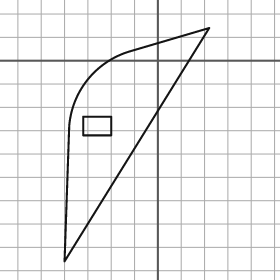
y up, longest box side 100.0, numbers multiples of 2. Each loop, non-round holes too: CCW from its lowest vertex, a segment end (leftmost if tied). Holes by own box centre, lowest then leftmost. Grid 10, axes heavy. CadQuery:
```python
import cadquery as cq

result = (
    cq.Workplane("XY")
    .moveTo(-40.0, -86.0)
    .lineTo(22.0, 14.0)
    .lineTo(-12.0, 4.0)
    .threePointArc((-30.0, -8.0), (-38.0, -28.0))
    .close()
    .moveTo(-32.0, -32.0)
    .lineTo(-20.0, -32.0)
    .lineTo(-20.0, -24.0)
    .lineTo(-32.0, -24.0)
    .close()
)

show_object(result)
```